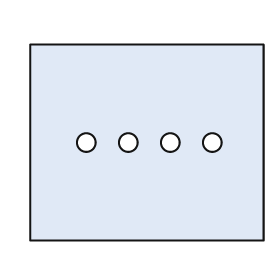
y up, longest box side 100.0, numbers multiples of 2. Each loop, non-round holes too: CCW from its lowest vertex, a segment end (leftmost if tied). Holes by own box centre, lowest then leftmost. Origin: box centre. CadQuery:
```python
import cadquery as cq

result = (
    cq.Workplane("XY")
    .moveTo(-50.0, -42.0)
    .lineTo(50.0, -42.0)
    .lineTo(50.0, 42.0)
    .lineTo(-50.0, 42.0)
    .close()
    .moveTo(-26.0, 0.0)
    .circle(4.0)
    .moveTo(-8.0, 0.0)
    .circle(4.0)
    .moveTo(10.0, 0.0)
    .circle(4.0)
    .moveTo(28.0, 0.0)
    .circle(4.0)
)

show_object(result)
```